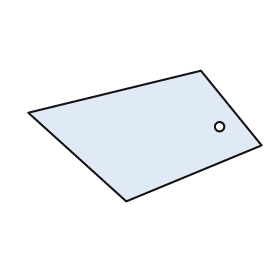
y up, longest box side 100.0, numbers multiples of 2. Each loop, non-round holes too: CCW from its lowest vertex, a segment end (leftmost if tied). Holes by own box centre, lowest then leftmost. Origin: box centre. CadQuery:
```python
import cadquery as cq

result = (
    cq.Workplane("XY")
    .moveTo(-8.0, -28.0)
    .lineTo(50.0, -4.0)
    .lineTo(24.0, 28.0)
    .lineTo(-50.0, 10.0)
    .close()
    .moveTo(32.0, 4.0)
    .circle(2.0)
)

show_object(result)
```